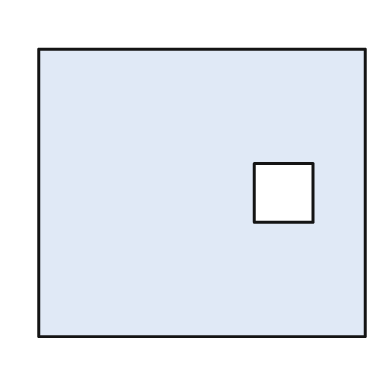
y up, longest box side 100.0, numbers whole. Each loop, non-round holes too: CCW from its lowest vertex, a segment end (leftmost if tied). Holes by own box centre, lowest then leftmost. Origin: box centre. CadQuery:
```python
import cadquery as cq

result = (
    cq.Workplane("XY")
    .moveTo(-50.0, -44.0)
    .lineTo(50.0, -44.0)
    .lineTo(50.0, 44.0)
    .lineTo(-50.0, 44.0)
    .close()
    .moveTo(16.0, -9.0)
    .lineTo(34.0, -9.0)
    .lineTo(34.0, 9.0)
    .lineTo(16.0, 9.0)
    .close()
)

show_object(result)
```